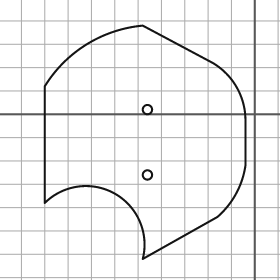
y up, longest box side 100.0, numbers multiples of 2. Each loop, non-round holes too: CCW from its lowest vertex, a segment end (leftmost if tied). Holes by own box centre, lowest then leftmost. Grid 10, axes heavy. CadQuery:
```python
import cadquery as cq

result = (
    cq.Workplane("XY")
    .moveTo(-48.0, -62.0)
    .lineTo(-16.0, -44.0)
    .threePointArc((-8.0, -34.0), (-4.0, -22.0))
    .lineTo(-4.0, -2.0)
    .threePointArc((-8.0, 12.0), (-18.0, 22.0))
    .lineTo(-48.0, 38.0)
    .threePointArc((-72.0, 30.0), (-90.0, 12.0))
    .lineTo(-90.0, -38.0)
    .threePointArc((-60.0, -34.0), (-48.0, -62.0))
    .close()
    .moveTo(-46.0, -26.0)
    .circle(2.0)
    .moveTo(-46.0, 2.0)
    .circle(2.0)
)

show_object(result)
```